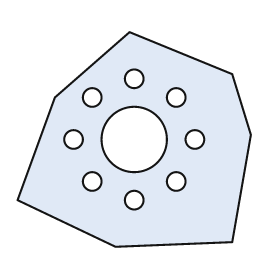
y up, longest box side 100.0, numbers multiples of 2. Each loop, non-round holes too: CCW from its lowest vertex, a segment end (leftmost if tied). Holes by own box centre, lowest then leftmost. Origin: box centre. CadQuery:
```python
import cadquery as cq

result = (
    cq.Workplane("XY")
    .moveTo(-8.0, -46.0)
    .lineTo(42.0, -44.0)
    .lineTo(50.0, 2.0)
    .lineTo(42.0, 28.0)
    .lineTo(-2.0, 46.0)
    .lineTo(-34.0, 18.0)
    .lineTo(-50.0, -26.0)
    .close()
    .moveTo(0.0, -26.0)
    .circle(4.0)
    .moveTo(-18.0, -18.0)
    .circle(4.0)
    .moveTo(18.0, -18.0)
    .circle(4.0)
    .moveTo(-26.0, 0.0)
    .circle(4.0)
    .moveTo(0.0, 0.0)
    .circle(14.0)
    .moveTo(26.0, 0.0)
    .circle(4.0)
    .moveTo(-18.0, 18.0)
    .circle(4.0)
    .moveTo(18.0, 18.0)
    .circle(4.0)
    .moveTo(0.0, 26.0)
    .circle(4.0)
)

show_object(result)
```